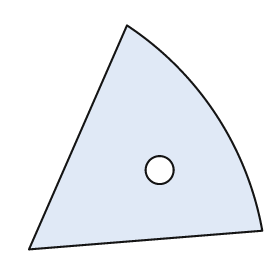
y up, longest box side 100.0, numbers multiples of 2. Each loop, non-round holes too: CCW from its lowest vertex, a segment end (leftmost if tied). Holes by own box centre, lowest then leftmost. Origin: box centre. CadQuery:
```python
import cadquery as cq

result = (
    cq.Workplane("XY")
    .moveTo(-50.0, -48.0)
    .lineTo(50.0, -40.0)
    .threePointArc((30.0, 10.0), (-8.0, 48.0))
    .close()
    .moveTo(6.0, -14.0)
    .circle(6.0)
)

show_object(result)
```